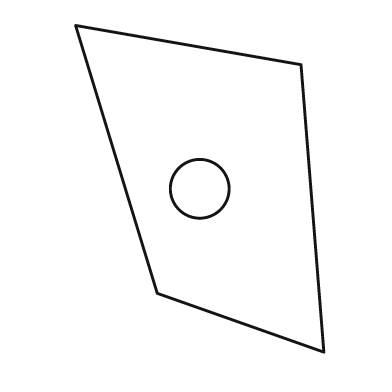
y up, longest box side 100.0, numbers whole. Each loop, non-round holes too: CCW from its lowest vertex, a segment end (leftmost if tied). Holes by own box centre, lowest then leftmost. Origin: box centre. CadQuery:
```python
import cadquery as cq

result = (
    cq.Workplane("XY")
    .moveTo(38.0, -50.0)
    .lineTo(31.0, 38.0)
    .lineTo(-38.0, 50.0)
    .lineTo(-13.0, -32.0)
    .close()
    .moveTo(0.0, 0.0)
    .circle(9.0)
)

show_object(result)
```